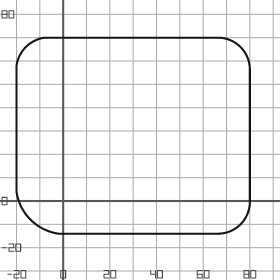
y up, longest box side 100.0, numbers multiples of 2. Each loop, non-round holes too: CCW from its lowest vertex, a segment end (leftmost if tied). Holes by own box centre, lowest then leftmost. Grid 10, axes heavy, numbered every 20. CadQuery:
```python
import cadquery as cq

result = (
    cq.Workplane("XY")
    .moveTo(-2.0, -14.0)
    .lineTo(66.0, -14.0)
    .threePointArc((76.0, -10.0), (80.0, 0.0))
    .lineTo(80.0, 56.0)
    .threePointArc((76.0, 66.0), (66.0, 70.0))
    .lineTo(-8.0, 70.0)
    .threePointArc((-16.0, 66.0), (-20.0, 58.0))
    .lineTo(-20.0, 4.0)
    .threePointArc((-14.0, -8.0), (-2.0, -14.0))
    .close()
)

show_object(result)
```